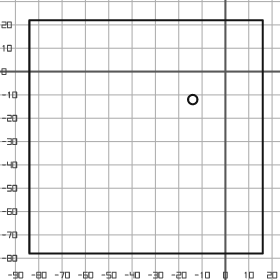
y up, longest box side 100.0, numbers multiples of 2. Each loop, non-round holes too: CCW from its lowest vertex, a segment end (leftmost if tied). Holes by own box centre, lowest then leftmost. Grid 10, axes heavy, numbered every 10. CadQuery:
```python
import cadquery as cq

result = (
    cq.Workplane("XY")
    .moveTo(-84.0, -78.0)
    .lineTo(16.0, -78.0)
    .lineTo(16.0, 22.0)
    .lineTo(-84.0, 22.0)
    .close()
    .moveTo(-14.0, -12.0)
    .circle(2.0)
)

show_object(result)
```